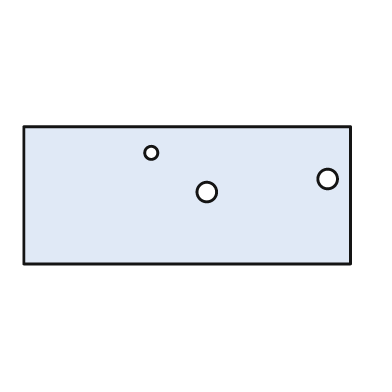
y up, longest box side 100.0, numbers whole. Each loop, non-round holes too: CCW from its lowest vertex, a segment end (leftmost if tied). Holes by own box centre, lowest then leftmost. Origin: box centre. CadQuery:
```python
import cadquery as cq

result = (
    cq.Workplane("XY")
    .moveTo(-50.0, -21.0)
    .lineTo(50.0, -21.0)
    .lineTo(50.0, 21.0)
    .lineTo(-50.0, 21.0)
    .close()
    .moveTo(6.0, 1.0)
    .circle(3.0)
    .moveTo(43.0, 5.0)
    .circle(3.0)
    .moveTo(-11.0, 13.0)
    .circle(2.0)
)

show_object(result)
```